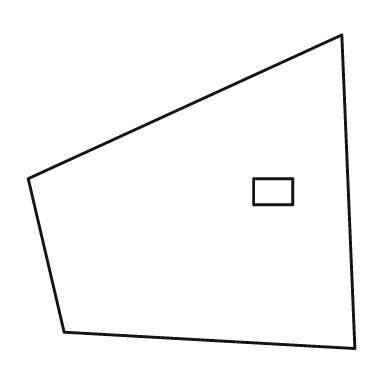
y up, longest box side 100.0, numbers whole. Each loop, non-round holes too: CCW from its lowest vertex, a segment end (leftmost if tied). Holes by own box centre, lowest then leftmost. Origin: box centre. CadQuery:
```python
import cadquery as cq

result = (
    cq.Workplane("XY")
    .moveTo(50.0, -48.0)
    .lineTo(46.0, 48.0)
    .lineTo(-50.0, 4.0)
    .lineTo(-39.0, -43.0)
    .close()
    .moveTo(19.0, -4.0)
    .lineTo(31.0, -4.0)
    .lineTo(31.0, 4.0)
    .lineTo(19.0, 4.0)
    .close()
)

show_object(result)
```